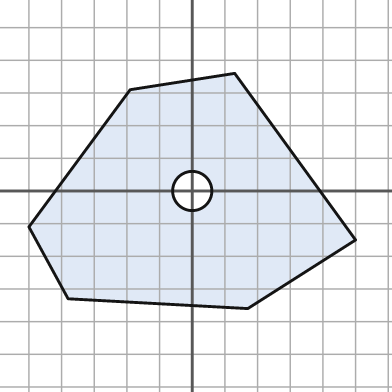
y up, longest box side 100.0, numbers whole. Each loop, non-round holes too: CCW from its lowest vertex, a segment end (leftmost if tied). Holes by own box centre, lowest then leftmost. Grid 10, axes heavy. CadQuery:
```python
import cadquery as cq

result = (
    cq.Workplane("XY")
    .moveTo(17.0, -36.0)
    .lineTo(50.0, -15.0)
    .lineTo(13.0, 36.0)
    .lineTo(-19.0, 31.0)
    .lineTo(-50.0, -11.0)
    .lineTo(-38.0, -33.0)
    .close()
    .moveTo(0.0, 0.0)
    .circle(6.0)
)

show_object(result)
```